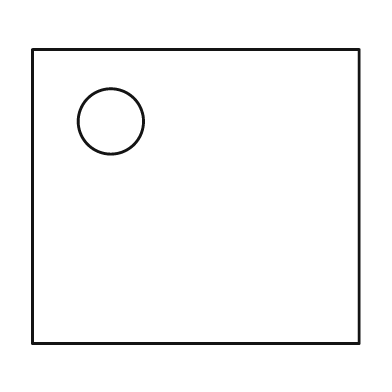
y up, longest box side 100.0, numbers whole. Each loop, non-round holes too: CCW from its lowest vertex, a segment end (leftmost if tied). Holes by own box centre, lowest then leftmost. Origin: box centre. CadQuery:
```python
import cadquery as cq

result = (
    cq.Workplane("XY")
    .moveTo(-50.0, -45.0)
    .lineTo(50.0, -45.0)
    .lineTo(50.0, 45.0)
    .lineTo(-50.0, 45.0)
    .close()
    .moveTo(-26.0, 23.0)
    .circle(10.0)
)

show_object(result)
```